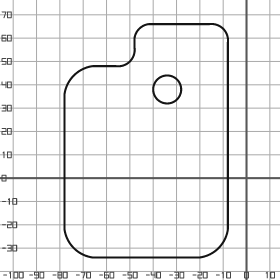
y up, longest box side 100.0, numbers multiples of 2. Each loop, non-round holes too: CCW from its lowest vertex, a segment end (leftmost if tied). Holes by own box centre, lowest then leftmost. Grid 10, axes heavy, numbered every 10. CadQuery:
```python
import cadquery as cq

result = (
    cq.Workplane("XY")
    .moveTo(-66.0, -34.0)
    .lineTo(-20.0, -34.0)
    .threePointArc((-12.0, -30.0), (-8.0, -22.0))
    .lineTo(-8.0, 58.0)
    .threePointArc((-10.0, 64.0), (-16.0, 66.0))
    .lineTo(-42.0, 66.0)
    .threePointArc((-46.0, 64.0), (-48.0, 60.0))
    .lineTo(-48.0, 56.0)
    .threePointArc((-50.0, 50.0), (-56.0, 48.0))
    .lineTo(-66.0, 48.0)
    .threePointArc((-74.0, 44.0), (-78.0, 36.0))
    .lineTo(-78.0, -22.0)
    .threePointArc((-74.0, -30.0), (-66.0, -34.0))
    .close()
    .moveTo(-34.0, 38.0)
    .circle(6.0)
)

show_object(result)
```